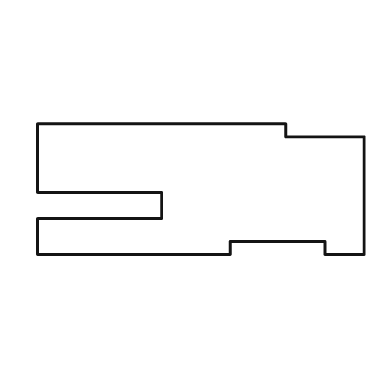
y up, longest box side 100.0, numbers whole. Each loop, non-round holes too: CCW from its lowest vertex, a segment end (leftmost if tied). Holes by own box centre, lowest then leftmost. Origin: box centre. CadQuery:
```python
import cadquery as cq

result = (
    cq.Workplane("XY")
    .moveTo(-50.0, -20.0)
    .lineTo(9.0, -20.0)
    .lineTo(9.0, -16.0)
    .lineTo(38.0, -16.0)
    .lineTo(38.0, -20.0)
    .lineTo(50.0, -20.0)
    .lineTo(50.0, 16.0)
    .lineTo(26.0, 16.0)
    .lineTo(26.0, 20.0)
    .lineTo(-50.0, 20.0)
    .lineTo(-50.0, -1.0)
    .lineTo(-12.0, -1.0)
    .lineTo(-12.0, -9.0)
    .lineTo(-50.0, -9.0)
    .close()
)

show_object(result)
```